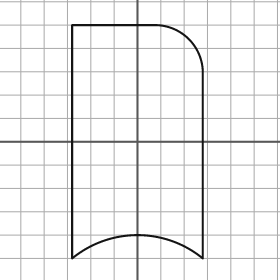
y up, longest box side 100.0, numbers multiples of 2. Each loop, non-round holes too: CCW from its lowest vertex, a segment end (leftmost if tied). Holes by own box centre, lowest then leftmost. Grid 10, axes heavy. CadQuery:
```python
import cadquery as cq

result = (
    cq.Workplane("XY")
    .moveTo(-28.0, -50.0)
    .threePointArc((0.0, -40.0), (28.0, -50.0))
    .lineTo(28.0, 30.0)
    .threePointArc((22.0, 44.0), (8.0, 50.0))
    .lineTo(-28.0, 50.0)
    .close()
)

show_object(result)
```